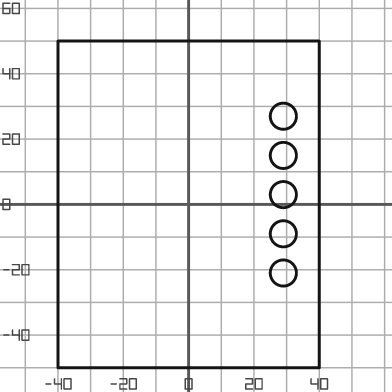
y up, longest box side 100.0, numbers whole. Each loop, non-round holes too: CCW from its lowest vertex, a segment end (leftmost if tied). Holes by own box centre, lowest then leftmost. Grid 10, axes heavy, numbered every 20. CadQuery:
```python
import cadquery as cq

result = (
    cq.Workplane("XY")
    .moveTo(-40.0, -50.0)
    .lineTo(40.0, -50.0)
    .lineTo(40.0, 50.0)
    .lineTo(-40.0, 50.0)
    .close()
    .moveTo(29.0, -21.0)
    .circle(4.0)
    .moveTo(29.0, -9.0)
    .circle(4.0)
    .moveTo(29.0, 3.0)
    .circle(4.0)
    .moveTo(29.0, 15.0)
    .circle(4.0)
    .moveTo(29.0, 27.0)
    .circle(4.0)
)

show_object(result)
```